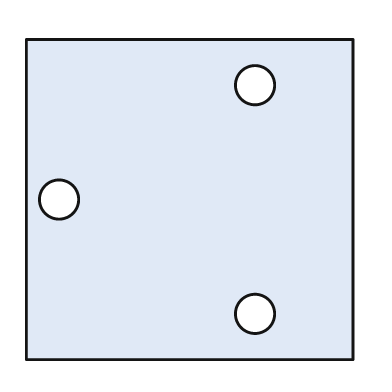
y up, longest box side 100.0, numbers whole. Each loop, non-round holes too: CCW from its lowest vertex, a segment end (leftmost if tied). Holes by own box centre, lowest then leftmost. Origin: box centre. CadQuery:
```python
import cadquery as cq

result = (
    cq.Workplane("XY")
    .moveTo(-50.0, -49.0)
    .lineTo(50.0, -49.0)
    .lineTo(50.0, 49.0)
    .lineTo(-50.0, 49.0)
    .close()
    .moveTo(20.0, -35.0)
    .circle(6.0)
    .moveTo(-40.0, 0.0)
    .circle(6.0)
    .moveTo(20.0, 35.0)
    .circle(6.0)
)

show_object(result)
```